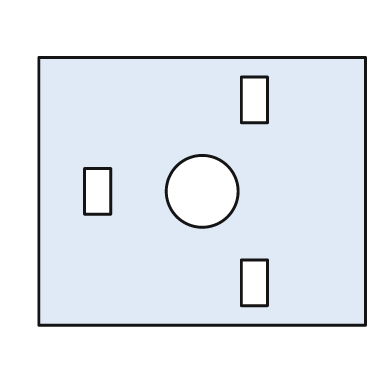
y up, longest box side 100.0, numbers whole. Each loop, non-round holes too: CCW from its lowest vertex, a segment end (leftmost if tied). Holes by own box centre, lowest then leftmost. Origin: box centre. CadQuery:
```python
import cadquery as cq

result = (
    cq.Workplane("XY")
    .moveTo(-50.0, -41.0)
    .lineTo(50.0, -41.0)
    .lineTo(50.0, 41.0)
    .lineTo(-50.0, 41.0)
    .close()
    .moveTo(12.0, -35.0)
    .lineTo(20.0, -35.0)
    .lineTo(20.0, -21.0)
    .lineTo(12.0, -21.0)
    .close()
    .moveTo(-36.0, -7.0)
    .lineTo(-28.0, -7.0)
    .lineTo(-28.0, 7.0)
    .lineTo(-36.0, 7.0)
    .close()
    .moveTo(0.0, 0.0)
    .circle(11.0)
    .moveTo(12.0, 21.0)
    .lineTo(20.0, 21.0)
    .lineTo(20.0, 35.0)
    .lineTo(12.0, 35.0)
    .close()
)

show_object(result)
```